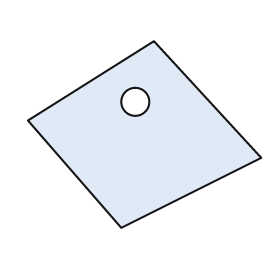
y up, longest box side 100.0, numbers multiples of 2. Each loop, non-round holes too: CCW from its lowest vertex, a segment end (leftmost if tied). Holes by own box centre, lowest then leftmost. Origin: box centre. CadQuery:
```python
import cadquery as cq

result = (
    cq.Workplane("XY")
    .moveTo(-10.0, -40.0)
    .lineTo(50.0, -10.0)
    .lineTo(4.0, 40.0)
    .lineTo(-50.0, 6.0)
    .close()
    .moveTo(-4.0, 14.0)
    .circle(6.0)
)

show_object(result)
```